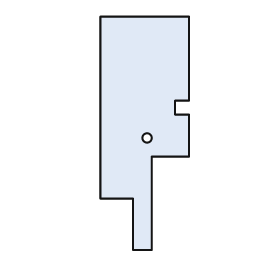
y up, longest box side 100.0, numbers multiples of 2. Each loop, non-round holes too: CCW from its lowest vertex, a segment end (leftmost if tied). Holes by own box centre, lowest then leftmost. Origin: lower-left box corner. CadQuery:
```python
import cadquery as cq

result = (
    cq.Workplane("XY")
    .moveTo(14.0, 0.0)
    .lineTo(22.0, 0.0)
    .lineTo(22.0, 40.0)
    .lineTo(38.0, 40.0)
    .lineTo(38.0, 58.0)
    .lineTo(32.0, 58.0)
    .lineTo(32.0, 64.0)
    .lineTo(38.0, 64.0)
    .lineTo(38.0, 100.0)
    .lineTo(0.0, 100.0)
    .lineTo(0.0, 22.0)
    .lineTo(14.0, 22.0)
    .close()
    .moveTo(20.0, 48.0)
    .circle(2.0)
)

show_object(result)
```